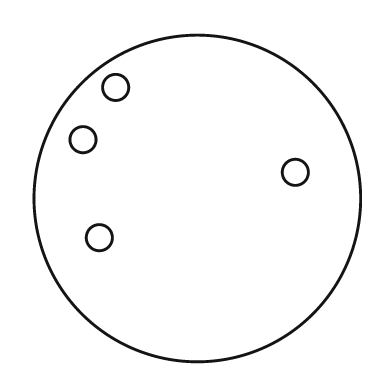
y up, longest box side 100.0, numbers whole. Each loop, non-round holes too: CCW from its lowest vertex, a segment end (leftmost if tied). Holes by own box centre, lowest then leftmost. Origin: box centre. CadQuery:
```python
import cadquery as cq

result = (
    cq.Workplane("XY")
    .moveTo(0.0, 0.0)
    .circle(50.0)
    .moveTo(-30.0, -12.0)
    .circle(4.0)
    .moveTo(30.0, 8.0)
    .circle(4.0)
    .moveTo(-35.0, 18.0)
    .circle(4.0)
    .moveTo(-25.0, 34.0)
    .circle(4.0)
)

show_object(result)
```